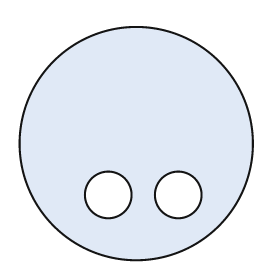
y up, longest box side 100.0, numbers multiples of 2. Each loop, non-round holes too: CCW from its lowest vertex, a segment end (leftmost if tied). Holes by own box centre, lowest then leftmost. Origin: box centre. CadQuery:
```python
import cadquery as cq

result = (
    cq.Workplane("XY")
    .moveTo(0.0, 0.0)
    .circle(50.0)
    .moveTo(-12.0, -22.0)
    .circle(10.0)
    .moveTo(18.0, -22.0)
    .circle(10.0)
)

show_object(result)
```